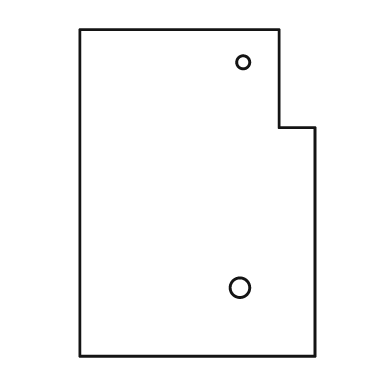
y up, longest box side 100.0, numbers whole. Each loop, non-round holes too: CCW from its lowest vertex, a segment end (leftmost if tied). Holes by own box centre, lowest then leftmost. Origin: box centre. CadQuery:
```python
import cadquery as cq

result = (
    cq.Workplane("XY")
    .moveTo(-36.0, -50.0)
    .lineTo(36.0, -50.0)
    .lineTo(36.0, 20.0)
    .lineTo(25.0, 20.0)
    .lineTo(25.0, 50.0)
    .lineTo(-36.0, 50.0)
    .close()
    .moveTo(13.0, -29.0)
    .circle(3.0)
    .moveTo(14.0, 40.0)
    .circle(2.0)
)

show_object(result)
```